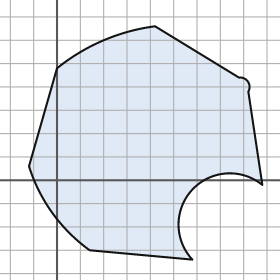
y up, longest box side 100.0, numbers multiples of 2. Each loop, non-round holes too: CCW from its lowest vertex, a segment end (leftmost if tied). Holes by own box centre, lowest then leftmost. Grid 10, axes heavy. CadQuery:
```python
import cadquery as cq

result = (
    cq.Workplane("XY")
    .moveTo(58.0, -34.0)
    .threePointArc((58.0, -4.0), (88.0, -2.0))
    .lineTo(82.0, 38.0)
    .threePointArc((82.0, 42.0), (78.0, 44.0))
    .lineTo(42.0, 66.0)
    .threePointArc((20.0, 60.0), (0.0, 48.0))
    .lineTo(-12.0, 6.0)
    .threePointArc((-2.0, -14.0), (14.0, -30.0))
    .close()
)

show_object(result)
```